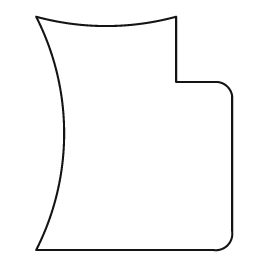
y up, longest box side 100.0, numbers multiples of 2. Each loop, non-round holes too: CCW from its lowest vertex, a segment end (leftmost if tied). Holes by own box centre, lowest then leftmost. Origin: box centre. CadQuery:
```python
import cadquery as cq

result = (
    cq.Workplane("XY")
    .moveTo(-42.0, -50.0)
    .lineTo(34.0, -50.0)
    .threePointArc((40.0, -48.0), (42.0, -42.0))
    .lineTo(42.0, 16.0)
    .threePointArc((40.0, 20.0), (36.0, 22.0))
    .lineTo(18.0, 22.0)
    .lineTo(18.0, 50.0)
    .threePointArc((-12.0, 46.0), (-42.0, 50.0))
    .threePointArc((-30.0, 0.0), (-42.0, -50.0))
    .close()
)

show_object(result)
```